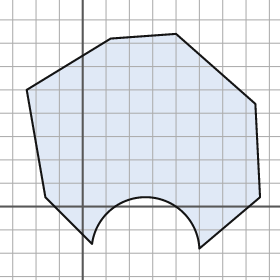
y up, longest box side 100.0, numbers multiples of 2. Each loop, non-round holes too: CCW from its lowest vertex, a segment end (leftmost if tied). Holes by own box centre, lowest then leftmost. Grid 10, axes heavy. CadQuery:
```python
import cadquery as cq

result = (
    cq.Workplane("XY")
    .moveTo(50.0, -18.0)
    .lineTo(76.0, 4.0)
    .lineTo(74.0, 44.0)
    .lineTo(40.0, 74.0)
    .lineTo(12.0, 72.0)
    .lineTo(-24.0, 50.0)
    .lineTo(-16.0, 4.0)
    .lineTo(4.0, -16.0)
    .threePointArc((28.0, 4.0), (50.0, -18.0))
    .close()
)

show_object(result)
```